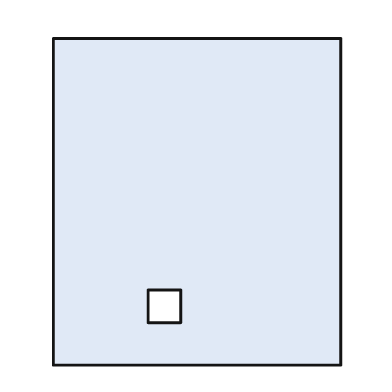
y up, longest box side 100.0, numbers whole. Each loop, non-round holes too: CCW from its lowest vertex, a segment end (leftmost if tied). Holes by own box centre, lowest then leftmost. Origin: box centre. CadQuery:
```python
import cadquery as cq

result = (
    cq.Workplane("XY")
    .moveTo(-44.0, -50.0)
    .lineTo(44.0, -50.0)
    .lineTo(44.0, 50.0)
    .lineTo(-44.0, 50.0)
    .close()
    .moveTo(-15.0, -37.0)
    .lineTo(-5.0, -37.0)
    .lineTo(-5.0, -27.0)
    .lineTo(-15.0, -27.0)
    .close()
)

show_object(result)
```